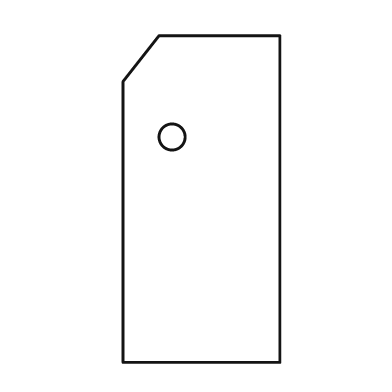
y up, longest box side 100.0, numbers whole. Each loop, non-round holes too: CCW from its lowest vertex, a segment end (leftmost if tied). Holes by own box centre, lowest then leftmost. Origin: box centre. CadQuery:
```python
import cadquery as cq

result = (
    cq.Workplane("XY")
    .moveTo(-24.0, -50.0)
    .lineTo(24.0, -50.0)
    .lineTo(24.0, 50.0)
    .lineTo(-13.0, 50.0)
    .lineTo(-24.0, 36.0)
    .close()
    .moveTo(-9.0, 19.0)
    .circle(4.0)
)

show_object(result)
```